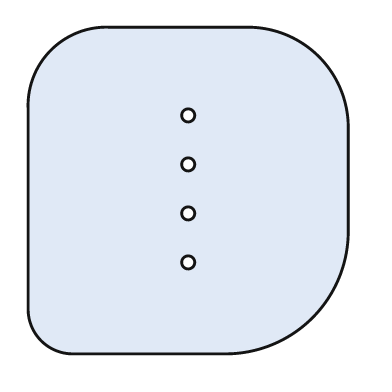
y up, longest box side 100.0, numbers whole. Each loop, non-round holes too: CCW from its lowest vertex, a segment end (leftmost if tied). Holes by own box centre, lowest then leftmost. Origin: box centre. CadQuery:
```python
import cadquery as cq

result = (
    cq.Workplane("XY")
    .moveTo(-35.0, -50.0)
    .lineTo(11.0, -50.0)
    .threePointArc((38.0, -39.0), (49.0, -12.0))
    .lineTo(49.0, 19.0)
    .threePointArc((40.0, 41.0), (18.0, 50.0))
    .lineTo(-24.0, 50.0)
    .threePointArc((-42.0, 43.0), (-49.0, 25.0))
    .lineTo(-49.0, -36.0)
    .threePointArc((-45.0, -46.0), (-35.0, -50.0))
    .close()
    .moveTo(0.0, -22.0)
    .circle(2.0)
    .moveTo(0.0, -7.0)
    .circle(2.0)
    .moveTo(0.0, 8.0)
    .circle(2.0)
    .moveTo(0.0, 23.0)
    .circle(2.0)
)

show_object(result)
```